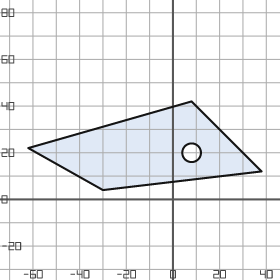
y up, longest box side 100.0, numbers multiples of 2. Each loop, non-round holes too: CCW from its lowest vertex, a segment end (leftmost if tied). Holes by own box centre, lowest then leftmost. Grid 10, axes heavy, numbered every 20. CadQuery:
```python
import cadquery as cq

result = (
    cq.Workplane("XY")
    .moveTo(-30.0, 4.0)
    .lineTo(38.0, 12.0)
    .lineTo(8.0, 42.0)
    .lineTo(-62.0, 22.0)
    .close()
    .moveTo(8.0, 20.0)
    .circle(4.0)
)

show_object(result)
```